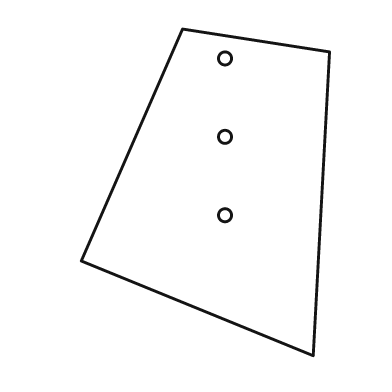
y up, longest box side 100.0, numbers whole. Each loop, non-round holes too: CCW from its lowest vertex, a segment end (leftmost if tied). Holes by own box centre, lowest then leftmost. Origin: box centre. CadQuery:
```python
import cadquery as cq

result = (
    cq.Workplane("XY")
    .moveTo(33.0, -50.0)
    .lineTo(38.0, 43.0)
    .lineTo(-7.0, 50.0)
    .lineTo(-38.0, -21.0)
    .close()
    .moveTo(6.0, -7.0)
    .circle(2.0)
    .moveTo(6.0, 17.0)
    .circle(2.0)
    .moveTo(6.0, 41.0)
    .circle(2.0)
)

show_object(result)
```